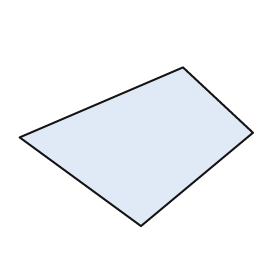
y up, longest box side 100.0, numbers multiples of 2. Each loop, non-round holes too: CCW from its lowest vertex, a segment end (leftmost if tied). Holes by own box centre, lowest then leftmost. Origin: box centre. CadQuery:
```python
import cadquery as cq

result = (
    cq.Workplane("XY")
    .moveTo(2.0, -34.0)
    .lineTo(50.0, 6.0)
    .lineTo(20.0, 34.0)
    .lineTo(-50.0, 4.0)
    .close()
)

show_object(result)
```